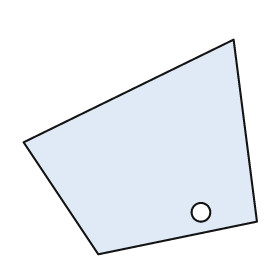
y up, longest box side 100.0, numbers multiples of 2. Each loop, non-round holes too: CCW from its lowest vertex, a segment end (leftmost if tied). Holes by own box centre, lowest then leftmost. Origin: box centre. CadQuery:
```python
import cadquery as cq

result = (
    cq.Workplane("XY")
    .moveTo(-18.0, -46.0)
    .lineTo(50.0, -32.0)
    .lineTo(40.0, 46.0)
    .lineTo(-50.0, 2.0)
    .close()
    .moveTo(26.0, -28.0)
    .circle(4.0)
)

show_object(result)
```